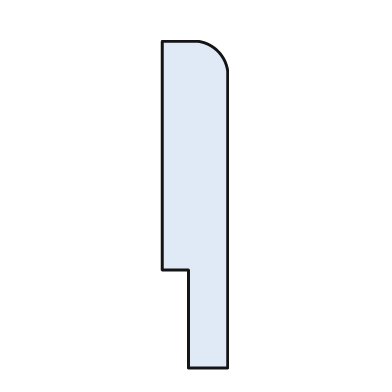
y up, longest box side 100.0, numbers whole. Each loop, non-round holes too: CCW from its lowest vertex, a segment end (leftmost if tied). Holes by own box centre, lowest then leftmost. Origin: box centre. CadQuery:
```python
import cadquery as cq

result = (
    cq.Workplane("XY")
    .moveTo(-2.0, -50.0)
    .lineTo(10.0, -50.0)
    .lineTo(10.0, 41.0)
    .threePointArc((7.0, 47.0), (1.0, 50.0))
    .lineTo(-10.0, 50.0)
    .lineTo(-10.0, -20.0)
    .lineTo(-2.0, -20.0)
    .close()
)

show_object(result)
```